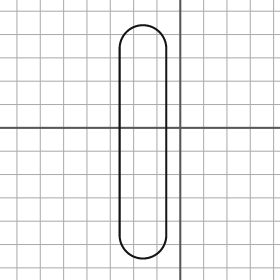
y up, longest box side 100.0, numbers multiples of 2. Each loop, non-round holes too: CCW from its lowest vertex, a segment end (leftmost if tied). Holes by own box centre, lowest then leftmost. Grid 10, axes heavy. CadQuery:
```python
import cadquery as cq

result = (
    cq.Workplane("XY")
    .moveTo(-26.0, -46.0)
    .threePointArc((-16.0, -56.0), (-6.0, -46.0))
    .lineTo(-6.0, 34.0)
    .threePointArc((-16.0, 44.0), (-26.0, 34.0))
    .close()
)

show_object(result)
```